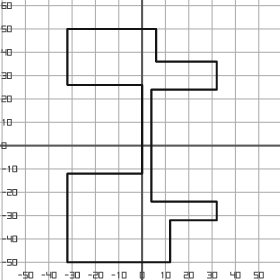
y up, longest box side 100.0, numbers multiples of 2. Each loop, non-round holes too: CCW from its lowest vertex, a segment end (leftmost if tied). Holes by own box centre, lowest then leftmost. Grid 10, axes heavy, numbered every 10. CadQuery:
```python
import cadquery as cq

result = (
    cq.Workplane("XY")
    .moveTo(-32.0, -50.0)
    .lineTo(12.0, -50.0)
    .lineTo(12.0, -32.0)
    .lineTo(32.0, -32.0)
    .lineTo(32.0, -24.0)
    .lineTo(4.0, -24.0)
    .lineTo(4.0, 24.0)
    .lineTo(32.0, 24.0)
    .lineTo(32.0, 36.0)
    .lineTo(6.0, 36.0)
    .lineTo(6.0, 50.0)
    .lineTo(-32.0, 50.0)
    .lineTo(-32.0, 26.0)
    .lineTo(0.0, 26.0)
    .lineTo(0.0, -12.0)
    .lineTo(-32.0, -12.0)
    .close()
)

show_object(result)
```